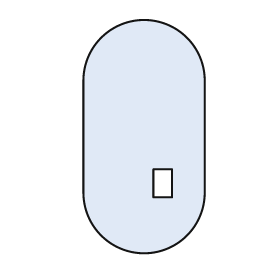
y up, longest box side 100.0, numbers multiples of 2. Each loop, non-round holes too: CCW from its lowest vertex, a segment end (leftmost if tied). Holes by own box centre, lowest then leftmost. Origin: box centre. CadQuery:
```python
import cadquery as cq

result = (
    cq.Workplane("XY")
    .moveTo(-26.0, -24.0)
    .threePointArc((0.0, -50.0), (26.0, -24.0))
    .lineTo(26.0, 24.0)
    .threePointArc((0.0, 50.0), (-26.0, 24.0))
    .close()
    .moveTo(4.0, -26.0)
    .lineTo(12.0, -26.0)
    .lineTo(12.0, -14.0)
    .lineTo(4.0, -14.0)
    .close()
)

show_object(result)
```